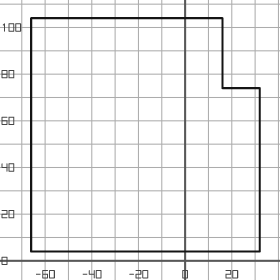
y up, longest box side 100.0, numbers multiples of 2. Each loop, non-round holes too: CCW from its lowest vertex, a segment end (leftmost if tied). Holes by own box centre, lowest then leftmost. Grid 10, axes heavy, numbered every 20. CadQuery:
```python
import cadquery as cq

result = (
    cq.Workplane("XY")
    .moveTo(-66.0, 4.0)
    .lineTo(32.0, 4.0)
    .lineTo(32.0, 74.0)
    .lineTo(16.0, 74.0)
    .lineTo(16.0, 104.0)
    .lineTo(-66.0, 104.0)
    .close()
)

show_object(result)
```